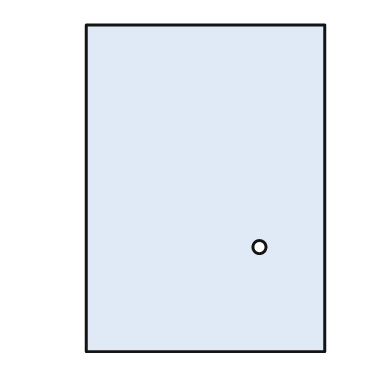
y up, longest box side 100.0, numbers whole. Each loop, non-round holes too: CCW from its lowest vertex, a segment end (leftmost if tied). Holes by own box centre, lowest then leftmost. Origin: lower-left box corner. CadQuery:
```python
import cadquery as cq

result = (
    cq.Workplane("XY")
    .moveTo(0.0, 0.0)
    .lineTo(73.0, 0.0)
    .lineTo(73.0, 100.0)
    .lineTo(0.0, 100.0)
    .close()
    .moveTo(53.0, 32.0)
    .circle(2.0)
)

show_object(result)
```